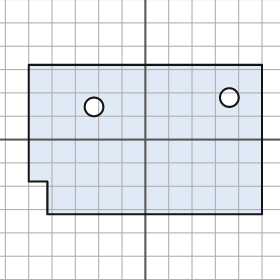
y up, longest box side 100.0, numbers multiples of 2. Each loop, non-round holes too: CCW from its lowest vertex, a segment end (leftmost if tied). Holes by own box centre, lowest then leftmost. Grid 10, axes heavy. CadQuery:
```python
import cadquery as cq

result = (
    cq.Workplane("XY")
    .moveTo(-42.0, -32.0)
    .lineTo(50.0, -32.0)
    .lineTo(50.0, 32.0)
    .lineTo(-50.0, 32.0)
    .lineTo(-50.0, -18.0)
    .lineTo(-42.0, -18.0)
    .close()
    .moveTo(-22.0, 14.0)
    .circle(4.0)
    .moveTo(36.0, 18.0)
    .circle(4.0)
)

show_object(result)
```